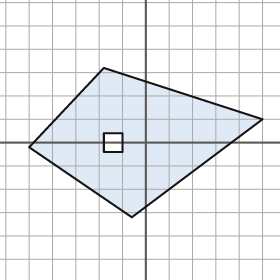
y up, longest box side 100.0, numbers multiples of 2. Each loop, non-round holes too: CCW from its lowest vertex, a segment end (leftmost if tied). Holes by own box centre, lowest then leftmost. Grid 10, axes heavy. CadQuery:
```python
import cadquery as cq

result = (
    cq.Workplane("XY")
    .moveTo(-6.0, -32.0)
    .lineTo(50.0, 10.0)
    .lineTo(-18.0, 32.0)
    .lineTo(-50.0, -2.0)
    .close()
    .moveTo(-18.0, -4.0)
    .lineTo(-10.0, -4.0)
    .lineTo(-10.0, 4.0)
    .lineTo(-18.0, 4.0)
    .close()
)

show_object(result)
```